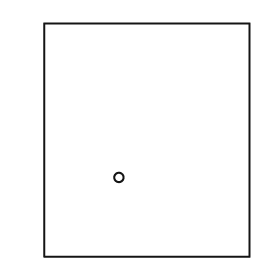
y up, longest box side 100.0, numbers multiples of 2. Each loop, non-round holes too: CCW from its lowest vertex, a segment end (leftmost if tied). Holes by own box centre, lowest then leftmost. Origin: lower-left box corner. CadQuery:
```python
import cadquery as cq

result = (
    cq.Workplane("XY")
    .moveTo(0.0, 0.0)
    .lineTo(88.0, 0.0)
    .lineTo(88.0, 100.0)
    .lineTo(0.0, 100.0)
    .close()
    .moveTo(32.0, 34.0)
    .circle(2.0)
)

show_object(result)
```